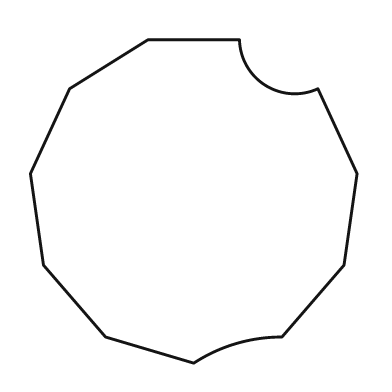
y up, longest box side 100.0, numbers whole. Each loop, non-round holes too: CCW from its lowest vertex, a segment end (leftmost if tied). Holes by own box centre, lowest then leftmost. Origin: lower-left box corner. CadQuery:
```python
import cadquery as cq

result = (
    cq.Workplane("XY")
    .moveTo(50.0, 0.0)
    .threePointArc((63.0, 6.0), (77.0, 8.0))
    .lineTo(96.0, 30.0)
    .lineTo(100.0, 58.0)
    .lineTo(88.0, 84.0)
    .threePointArc((72.0, 85.0), (64.0, 99.0))
    .lineTo(36.0, 99.0)
    .lineTo(12.0, 84.0)
    .lineTo(0.0, 58.0)
    .lineTo(4.0, 30.0)
    .lineTo(23.0, 8.0)
    .close()
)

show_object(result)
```